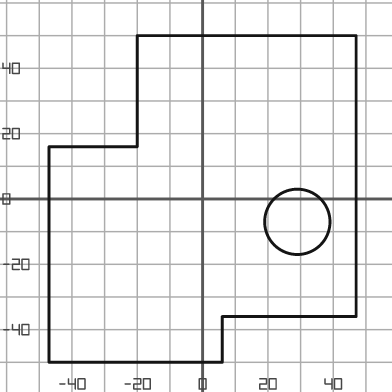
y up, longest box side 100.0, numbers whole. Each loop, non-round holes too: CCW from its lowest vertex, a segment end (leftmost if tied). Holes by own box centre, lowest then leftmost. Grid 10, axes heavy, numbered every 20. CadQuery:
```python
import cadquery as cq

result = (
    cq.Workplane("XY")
    .moveTo(-47.0, -50.0)
    .lineTo(6.0, -50.0)
    .lineTo(6.0, -36.0)
    .lineTo(47.0, -36.0)
    .lineTo(47.0, 50.0)
    .lineTo(-20.0, 50.0)
    .lineTo(-20.0, 16.0)
    .lineTo(-47.0, 16.0)
    .close()
    .moveTo(29.0, -7.0)
    .circle(10.0)
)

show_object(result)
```